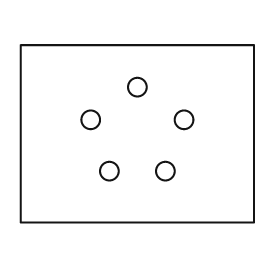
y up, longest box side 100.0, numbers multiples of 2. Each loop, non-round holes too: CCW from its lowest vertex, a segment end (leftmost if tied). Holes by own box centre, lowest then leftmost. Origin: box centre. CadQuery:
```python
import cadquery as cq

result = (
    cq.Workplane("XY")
    .moveTo(-50.0, -38.0)
    .lineTo(50.0, -38.0)
    .lineTo(50.0, 38.0)
    .lineTo(-50.0, 38.0)
    .close()
    .moveTo(-12.0, -16.0)
    .circle(4.0)
    .moveTo(12.0, -16.0)
    .circle(4.0)
    .moveTo(-20.0, 6.0)
    .circle(4.0)
    .moveTo(20.0, 6.0)
    .circle(4.0)
    .moveTo(0.0, 20.0)
    .circle(4.0)
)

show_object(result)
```